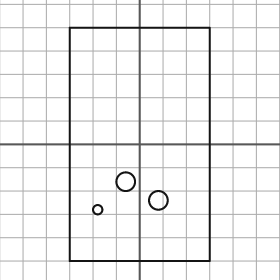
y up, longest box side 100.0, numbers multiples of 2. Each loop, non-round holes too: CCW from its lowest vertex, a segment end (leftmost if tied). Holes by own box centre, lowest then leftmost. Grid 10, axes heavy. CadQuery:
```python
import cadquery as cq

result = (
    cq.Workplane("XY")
    .moveTo(-30.0, -50.0)
    .lineTo(30.0, -50.0)
    .lineTo(30.0, 50.0)
    .lineTo(-30.0, 50.0)
    .close()
    .moveTo(-18.0, -28.0)
    .circle(2.0)
    .moveTo(8.0, -24.0)
    .circle(4.0)
    .moveTo(-6.0, -16.0)
    .circle(4.0)
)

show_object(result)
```